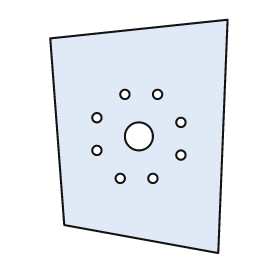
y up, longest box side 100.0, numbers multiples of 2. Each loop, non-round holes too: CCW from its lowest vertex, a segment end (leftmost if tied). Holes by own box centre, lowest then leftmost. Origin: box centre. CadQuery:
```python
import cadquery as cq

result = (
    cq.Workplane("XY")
    .moveTo(34.0, -50.0)
    .lineTo(38.0, 50.0)
    .lineTo(-38.0, 42.0)
    .lineTo(-32.0, -38.0)
    .close()
    .moveTo(-8.0, -18.0)
    .circle(2.0)
    .moveTo(6.0, -18.0)
    .circle(2.0)
    .moveTo(18.0, -8.0)
    .circle(2.0)
    .moveTo(-18.0, -6.0)
    .circle(2.0)
    .moveTo(0.0, 0.0)
    .circle(6.0)
    .moveTo(18.0, 6.0)
    .circle(2.0)
    .moveTo(-18.0, 8.0)
    .circle(2.0)
    .moveTo(-6.0, 18.0)
    .circle(2.0)
    .moveTo(8.0, 18.0)
    .circle(2.0)
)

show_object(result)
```